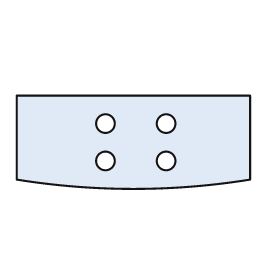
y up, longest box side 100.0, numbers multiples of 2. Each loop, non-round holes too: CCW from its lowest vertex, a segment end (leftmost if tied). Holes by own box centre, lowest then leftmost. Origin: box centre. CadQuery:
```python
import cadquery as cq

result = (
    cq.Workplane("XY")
    .moveTo(-50.0, -16.0)
    .threePointArc((0.0, -20.0), (50.0, -16.0))
    .lineTo(50.0, 20.0)
    .lineTo(-50.0, 20.0)
    .close()
    .moveTo(-12.0, -8.0)
    .circle(4.0)
    .moveTo(14.0, -8.0)
    .circle(4.0)
    .moveTo(-12.0, 8.0)
    .circle(4.0)
    .moveTo(14.0, 8.0)
    .circle(4.0)
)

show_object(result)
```